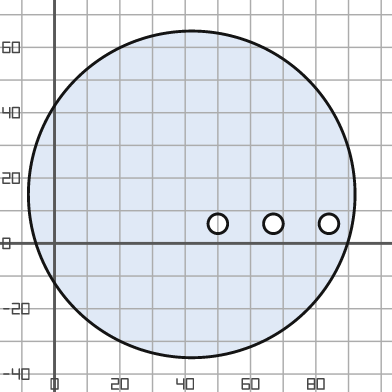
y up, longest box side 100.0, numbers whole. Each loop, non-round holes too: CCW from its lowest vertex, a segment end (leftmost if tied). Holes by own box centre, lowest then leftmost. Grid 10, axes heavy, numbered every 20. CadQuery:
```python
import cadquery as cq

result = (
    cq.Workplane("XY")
    .moveTo(42.0, 15.0)
    .circle(50.0)
    .moveTo(50.0, 6.0)
    .circle(3.0)
    .moveTo(67.0, 6.0)
    .circle(3.0)
    .moveTo(84.0, 6.0)
    .circle(3.0)
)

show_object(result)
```